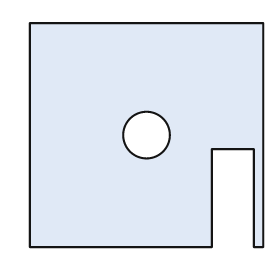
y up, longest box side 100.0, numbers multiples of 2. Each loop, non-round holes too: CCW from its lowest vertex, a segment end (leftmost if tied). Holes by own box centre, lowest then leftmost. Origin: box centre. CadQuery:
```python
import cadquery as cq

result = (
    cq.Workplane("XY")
    .moveTo(-50.0, -48.0)
    .lineTo(28.0, -48.0)
    .lineTo(28.0, -6.0)
    .lineTo(46.0, -6.0)
    .lineTo(46.0, -48.0)
    .lineTo(50.0, -48.0)
    .lineTo(50.0, 48.0)
    .lineTo(-50.0, 48.0)
    .close()
    .moveTo(0.0, 0.0)
    .circle(10.0)
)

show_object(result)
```